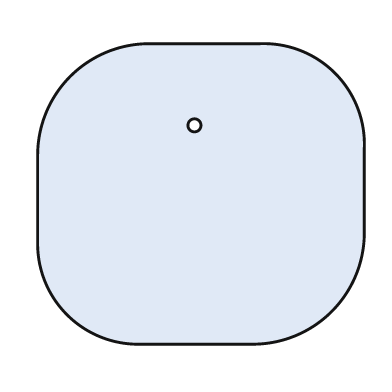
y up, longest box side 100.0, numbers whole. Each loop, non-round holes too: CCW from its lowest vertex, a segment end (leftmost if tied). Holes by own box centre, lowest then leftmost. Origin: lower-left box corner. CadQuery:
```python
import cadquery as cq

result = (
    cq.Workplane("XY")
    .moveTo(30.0, 0.0)
    .lineTo(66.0, 0.0)
    .threePointArc((90.0, 10.0), (100.0, 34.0))
    .lineTo(100.0, 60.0)
    .threePointArc((91.0, 83.0), (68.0, 92.0))
    .lineTo(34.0, 92.0)
    .threePointArc((10.0, 82.0), (0.0, 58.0))
    .lineTo(0.0, 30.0)
    .threePointArc((9.0, 9.0), (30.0, 0.0))
    .close()
    .moveTo(48.0, 67.0)
    .circle(2.0)
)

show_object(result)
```